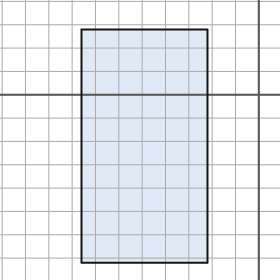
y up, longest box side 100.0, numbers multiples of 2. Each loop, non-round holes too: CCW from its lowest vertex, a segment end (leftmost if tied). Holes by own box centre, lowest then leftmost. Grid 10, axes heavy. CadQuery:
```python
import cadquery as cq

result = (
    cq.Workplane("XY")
    .moveTo(-76.0, -72.0)
    .lineTo(-22.0, -72.0)
    .lineTo(-22.0, 28.0)
    .lineTo(-76.0, 28.0)
    .close()
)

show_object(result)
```